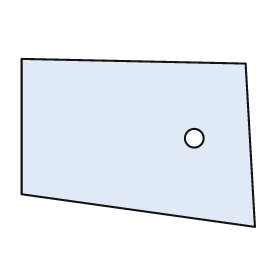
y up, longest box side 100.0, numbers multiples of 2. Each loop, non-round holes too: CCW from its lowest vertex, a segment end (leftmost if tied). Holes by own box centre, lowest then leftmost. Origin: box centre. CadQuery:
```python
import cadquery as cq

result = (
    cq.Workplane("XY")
    .moveTo(50.0, -36.0)
    .lineTo(46.0, 34.0)
    .lineTo(-50.0, 36.0)
    .lineTo(-50.0, -22.0)
    .close()
    .moveTo(24.0, 2.0)
    .circle(4.0)
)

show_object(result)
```